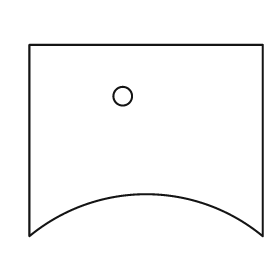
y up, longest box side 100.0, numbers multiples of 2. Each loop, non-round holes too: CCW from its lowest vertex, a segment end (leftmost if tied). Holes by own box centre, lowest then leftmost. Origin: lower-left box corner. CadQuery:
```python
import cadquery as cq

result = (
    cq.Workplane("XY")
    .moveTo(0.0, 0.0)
    .threePointArc((50.0, 18.0), (100.0, 0.0))
    .lineTo(100.0, 82.0)
    .lineTo(0.0, 82.0)
    .close()
    .moveTo(40.0, 60.0)
    .circle(4.0)
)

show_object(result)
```